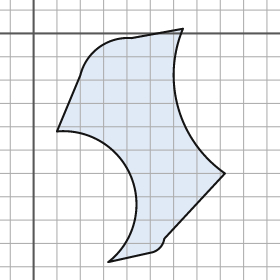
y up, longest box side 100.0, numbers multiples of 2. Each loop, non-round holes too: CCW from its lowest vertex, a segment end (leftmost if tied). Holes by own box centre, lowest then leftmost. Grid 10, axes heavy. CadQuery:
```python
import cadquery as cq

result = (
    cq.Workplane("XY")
    .moveTo(32.0, -98.0)
    .lineTo(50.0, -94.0)
    .threePointArc((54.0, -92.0), (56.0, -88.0))
    .lineTo(82.0, -60.0)
    .threePointArc((62.0, -32.0), (64.0, 2.0))
    .lineTo(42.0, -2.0)
    .threePointArc((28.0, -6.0), (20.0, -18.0))
    .lineTo(10.0, -42.0)
    .threePointArc((42.0, -62.0), (32.0, -98.0))
    .close()
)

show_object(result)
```